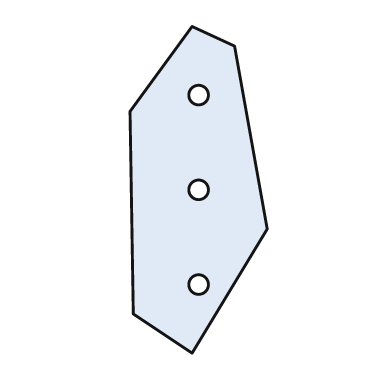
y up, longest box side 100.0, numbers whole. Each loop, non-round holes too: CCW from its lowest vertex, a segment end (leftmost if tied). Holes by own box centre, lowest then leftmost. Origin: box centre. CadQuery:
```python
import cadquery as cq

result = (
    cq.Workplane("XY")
    .moveTo(-2.0, -50.0)
    .lineTo(21.0, -12.0)
    .lineTo(11.0, 44.0)
    .lineTo(-2.0, 50.0)
    .lineTo(-21.0, 24.0)
    .lineTo(-20.0, -38.0)
    .close()
    .moveTo(0.0, -29.0)
    .circle(3.0)
    .moveTo(0.0, 0.0)
    .circle(3.0)
    .moveTo(0.0, 29.0)
    .circle(3.0)
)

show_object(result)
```